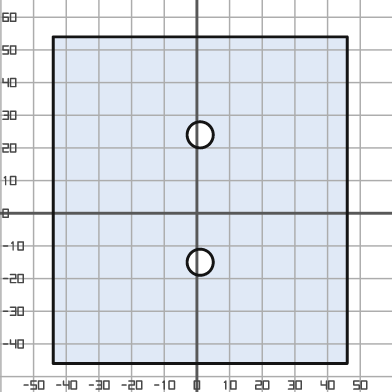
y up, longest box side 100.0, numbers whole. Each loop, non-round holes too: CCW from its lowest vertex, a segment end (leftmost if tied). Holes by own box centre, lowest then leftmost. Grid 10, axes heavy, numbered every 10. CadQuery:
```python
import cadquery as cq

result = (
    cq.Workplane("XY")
    .moveTo(-44.0, -46.0)
    .lineTo(46.0, -46.0)
    .lineTo(46.0, 54.0)
    .lineTo(-44.0, 54.0)
    .close()
    .moveTo(1.0, -15.0)
    .circle(4.0)
    .moveTo(1.0, 24.0)
    .circle(4.0)
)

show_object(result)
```